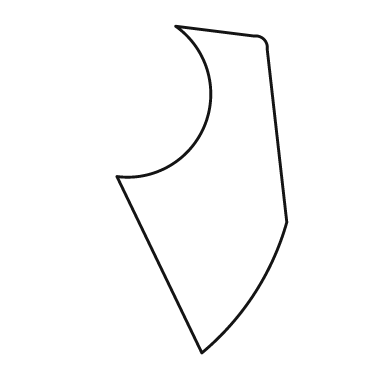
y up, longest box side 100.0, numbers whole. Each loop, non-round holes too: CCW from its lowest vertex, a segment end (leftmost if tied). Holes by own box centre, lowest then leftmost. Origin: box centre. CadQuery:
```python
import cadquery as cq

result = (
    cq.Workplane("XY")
    .moveTo(0.0, -50.0)
    .threePointArc((16.0, -32.0), (26.0, -10.0))
    .lineTo(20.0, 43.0)
    .threePointArc((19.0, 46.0), (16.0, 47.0))
    .lineTo(-8.0, 50.0)
    .threePointArc((1.0, 20.0), (-26.0, 4.0))
    .close()
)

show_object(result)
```